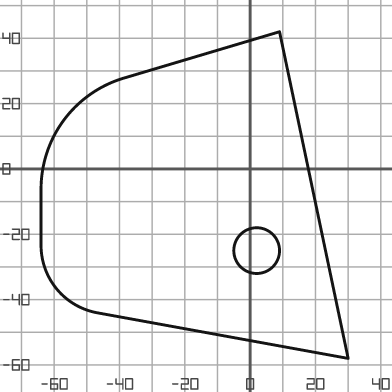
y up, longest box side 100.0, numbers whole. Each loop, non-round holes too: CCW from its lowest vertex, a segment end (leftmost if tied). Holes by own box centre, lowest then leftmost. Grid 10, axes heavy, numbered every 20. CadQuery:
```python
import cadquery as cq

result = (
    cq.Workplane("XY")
    .moveTo(30.0, -58.0)
    .lineTo(9.0, 42.0)
    .lineTo(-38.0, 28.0)
    .threePointArc((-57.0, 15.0), (-64.0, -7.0))
    .lineTo(-64.0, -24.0)
    .threePointArc((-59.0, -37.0), (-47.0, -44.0))
    .close()
    .moveTo(2.0, -25.0)
    .circle(7.0)
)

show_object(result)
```